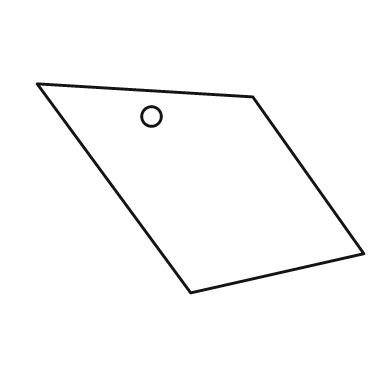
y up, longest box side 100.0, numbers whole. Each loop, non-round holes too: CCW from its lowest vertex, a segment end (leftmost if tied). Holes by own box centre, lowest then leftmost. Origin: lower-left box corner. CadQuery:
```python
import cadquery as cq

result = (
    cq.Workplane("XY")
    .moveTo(47.0, 0.0)
    .lineTo(100.0, 12.0)
    .lineTo(66.0, 60.0)
    .lineTo(0.0, 64.0)
    .close()
    .moveTo(35.0, 54.0)
    .circle(3.0)
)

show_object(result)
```